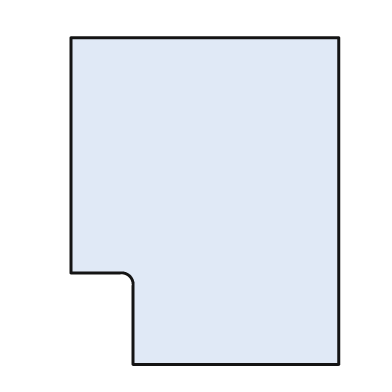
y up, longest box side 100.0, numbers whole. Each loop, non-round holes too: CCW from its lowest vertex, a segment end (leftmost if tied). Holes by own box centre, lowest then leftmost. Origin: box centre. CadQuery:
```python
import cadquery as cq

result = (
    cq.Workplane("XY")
    .moveTo(-22.0, -50.0)
    .lineTo(41.0, -50.0)
    .lineTo(41.0, 50.0)
    .lineTo(-41.0, 50.0)
    .lineTo(-41.0, -22.0)
    .lineTo(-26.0, -22.0)
    .threePointArc((-23.0, -23.0), (-22.0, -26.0))
    .close()
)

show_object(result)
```